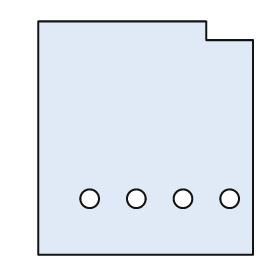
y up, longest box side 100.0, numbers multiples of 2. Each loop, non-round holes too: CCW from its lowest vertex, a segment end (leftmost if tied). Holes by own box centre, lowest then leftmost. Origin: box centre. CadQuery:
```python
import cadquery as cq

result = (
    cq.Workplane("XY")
    .moveTo(-46.0, -50.0)
    .lineTo(46.0, -50.0)
    .lineTo(46.0, 42.0)
    .lineTo(26.0, 42.0)
    .lineTo(26.0, 50.0)
    .lineTo(-46.0, 50.0)
    .close()
    .moveTo(-24.0, -26.0)
    .circle(4.0)
    .moveTo(-4.0, -26.0)
    .circle(4.0)
    .moveTo(16.0, -26.0)
    .circle(4.0)
    .moveTo(36.0, -26.0)
    .circle(4.0)
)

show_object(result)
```